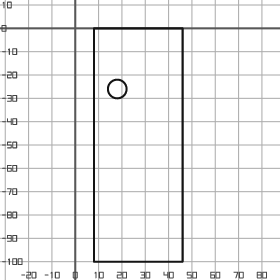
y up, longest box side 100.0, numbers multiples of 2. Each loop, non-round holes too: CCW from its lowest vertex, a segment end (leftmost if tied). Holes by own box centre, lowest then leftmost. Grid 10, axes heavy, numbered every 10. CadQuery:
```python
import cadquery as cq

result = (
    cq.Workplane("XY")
    .moveTo(8.0, -100.0)
    .lineTo(46.0, -100.0)
    .lineTo(46.0, 0.0)
    .lineTo(8.0, 0.0)
    .close()
    .moveTo(18.0, -26.0)
    .circle(4.0)
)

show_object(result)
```